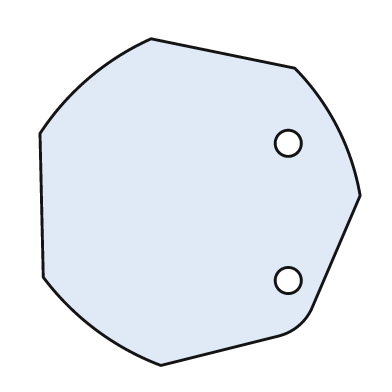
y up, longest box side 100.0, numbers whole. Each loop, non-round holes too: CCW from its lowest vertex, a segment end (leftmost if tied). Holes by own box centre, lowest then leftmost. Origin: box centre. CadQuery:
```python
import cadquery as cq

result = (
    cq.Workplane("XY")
    .moveTo(-12.0, -50.0)
    .lineTo(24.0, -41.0)
    .threePointArc((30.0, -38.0), (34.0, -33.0))
    .lineTo(49.0, 2.0)
    .threePointArc((42.0, 23.0), (29.0, 41.0))
    .lineTo(-15.0, 50.0)
    .threePointArc((-34.0, 38.0), (-49.0, 21.0))
    .lineTo(-48.0, -23.0)
    .threePointArc((-32.0, -39.0), (-12.0, -50.0))
    .close()
    .moveTo(27.0, -24.0)
    .circle(4.0)
    .moveTo(27.0, 18.0)
    .circle(4.0)
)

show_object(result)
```